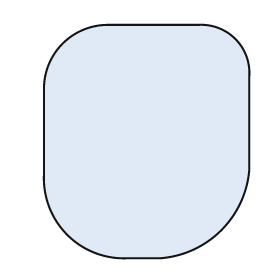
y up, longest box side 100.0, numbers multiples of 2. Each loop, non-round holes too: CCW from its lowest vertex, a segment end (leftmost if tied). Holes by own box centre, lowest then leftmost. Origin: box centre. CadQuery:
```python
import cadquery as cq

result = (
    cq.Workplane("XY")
    .moveTo(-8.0, -50.0)
    .lineTo(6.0, -50.0)
    .threePointArc((32.0, -38.0), (44.0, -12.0))
    .lineTo(44.0, 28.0)
    .threePointArc((38.0, 44.0), (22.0, 50.0))
    .lineTo(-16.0, 50.0)
    .threePointArc((-36.0, 42.0), (-44.0, 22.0))
    .lineTo(-44.0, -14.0)
    .threePointArc((-34.0, -40.0), (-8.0, -50.0))
    .close()
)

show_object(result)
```